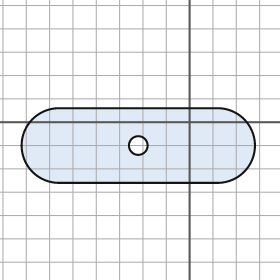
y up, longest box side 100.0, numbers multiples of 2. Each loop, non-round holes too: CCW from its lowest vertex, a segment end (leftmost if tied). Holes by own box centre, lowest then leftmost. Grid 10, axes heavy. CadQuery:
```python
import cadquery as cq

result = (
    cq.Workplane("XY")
    .moveTo(-56.0, -26.0)
    .lineTo(12.0, -26.0)
    .threePointArc((28.0, -10.0), (12.0, 6.0))
    .lineTo(-56.0, 6.0)
    .threePointArc((-72.0, -10.0), (-56.0, -26.0))
    .close()
    .moveTo(-22.0, -10.0)
    .circle(4.0)
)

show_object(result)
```